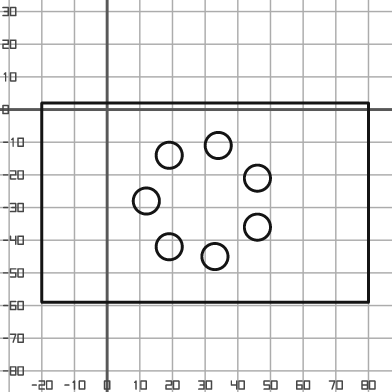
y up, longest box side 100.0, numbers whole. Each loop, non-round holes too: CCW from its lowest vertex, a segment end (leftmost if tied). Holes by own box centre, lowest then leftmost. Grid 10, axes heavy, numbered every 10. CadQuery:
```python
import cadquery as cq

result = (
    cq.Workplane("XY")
    .moveTo(-20.0, -59.0)
    .lineTo(80.0, -59.0)
    .lineTo(80.0, 2.0)
    .lineTo(-20.0, 2.0)
    .close()
    .moveTo(33.0, -45.0)
    .circle(4.0)
    .moveTo(19.0, -42.0)
    .circle(4.0)
    .moveTo(46.0, -36.0)
    .circle(4.0)
    .moveTo(12.0, -28.0)
    .circle(4.0)
    .moveTo(46.0, -21.0)
    .circle(4.0)
    .moveTo(19.0, -14.0)
    .circle(4.0)
    .moveTo(34.0, -11.0)
    .circle(4.0)
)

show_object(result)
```